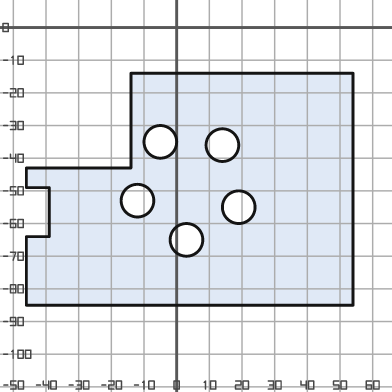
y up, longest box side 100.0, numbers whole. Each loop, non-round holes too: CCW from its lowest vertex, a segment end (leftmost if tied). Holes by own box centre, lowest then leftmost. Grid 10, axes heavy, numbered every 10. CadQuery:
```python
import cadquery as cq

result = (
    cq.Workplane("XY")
    .moveTo(-46.0, -85.0)
    .lineTo(54.0, -85.0)
    .lineTo(54.0, -14.0)
    .lineTo(-14.0, -14.0)
    .lineTo(-14.0, -43.0)
    .lineTo(-46.0, -43.0)
    .lineTo(-46.0, -49.0)
    .lineTo(-39.0, -49.0)
    .lineTo(-39.0, -64.0)
    .lineTo(-46.0, -64.0)
    .close()
    .moveTo(3.0, -65.0)
    .circle(5.0)
    .moveTo(19.0, -55.0)
    .circle(5.0)
    .moveTo(-12.0, -53.0)
    .circle(5.0)
    .moveTo(14.0, -36.0)
    .circle(5.0)
    .moveTo(-5.0, -35.0)
    .circle(5.0)
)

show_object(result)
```